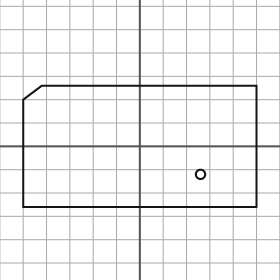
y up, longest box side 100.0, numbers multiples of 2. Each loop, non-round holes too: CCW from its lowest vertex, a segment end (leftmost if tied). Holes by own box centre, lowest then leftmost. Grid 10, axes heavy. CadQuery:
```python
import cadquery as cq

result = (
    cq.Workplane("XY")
    .moveTo(-50.0, -26.0)
    .lineTo(50.0, -26.0)
    .lineTo(50.0, 26.0)
    .lineTo(-42.0, 26.0)
    .lineTo(-50.0, 20.0)
    .close()
    .moveTo(26.0, -12.0)
    .circle(2.0)
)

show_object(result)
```